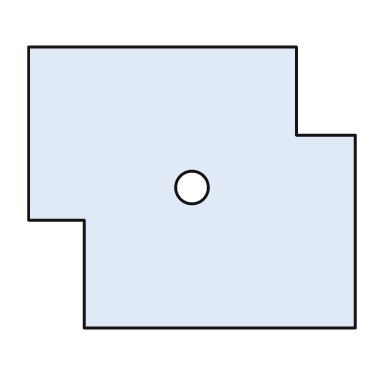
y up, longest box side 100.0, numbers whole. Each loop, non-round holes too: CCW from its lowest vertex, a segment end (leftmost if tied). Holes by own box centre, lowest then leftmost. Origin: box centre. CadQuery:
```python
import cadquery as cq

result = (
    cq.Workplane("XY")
    .moveTo(-33.0, -43.0)
    .lineTo(50.0, -43.0)
    .lineTo(50.0, 16.0)
    .lineTo(32.0, 16.0)
    .lineTo(32.0, 43.0)
    .lineTo(-50.0, 43.0)
    .lineTo(-50.0, -10.0)
    .lineTo(-33.0, -10.0)
    .close()
    .moveTo(0.0, 0.0)
    .circle(5.0)
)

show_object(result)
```